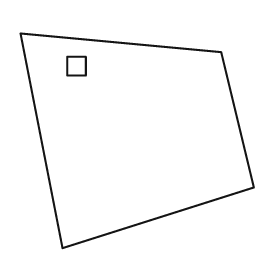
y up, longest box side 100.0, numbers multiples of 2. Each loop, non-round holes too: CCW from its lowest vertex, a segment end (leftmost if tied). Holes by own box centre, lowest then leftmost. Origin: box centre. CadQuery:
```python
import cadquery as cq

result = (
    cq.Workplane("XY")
    .moveTo(-32.0, -46.0)
    .lineTo(50.0, -20.0)
    .lineTo(36.0, 38.0)
    .lineTo(-50.0, 46.0)
    .close()
    .moveTo(-30.0, 28.0)
    .lineTo(-22.0, 28.0)
    .lineTo(-22.0, 36.0)
    .lineTo(-30.0, 36.0)
    .close()
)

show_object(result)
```